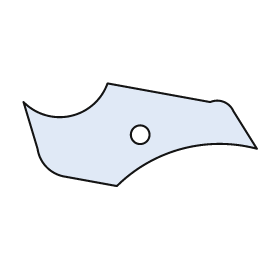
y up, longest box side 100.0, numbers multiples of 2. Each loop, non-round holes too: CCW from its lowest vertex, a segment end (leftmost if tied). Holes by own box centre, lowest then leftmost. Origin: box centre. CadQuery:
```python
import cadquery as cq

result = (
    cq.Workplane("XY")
    .moveTo(-10.0, -22.0)
    .threePointArc((18.0, -6.0), (50.0, -6.0))
    .lineTo(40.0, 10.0)
    .threePointArc((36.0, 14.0), (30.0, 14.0))
    .lineTo(-14.0, 22.0)
    .threePointArc((-30.0, 8.0), (-50.0, 14.0))
    .lineTo(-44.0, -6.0)
    .threePointArc((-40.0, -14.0), (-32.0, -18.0))
    .close()
    .moveTo(0.0, 0.0)
    .circle(4.0)
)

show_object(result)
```